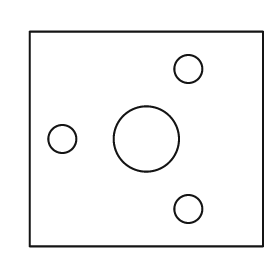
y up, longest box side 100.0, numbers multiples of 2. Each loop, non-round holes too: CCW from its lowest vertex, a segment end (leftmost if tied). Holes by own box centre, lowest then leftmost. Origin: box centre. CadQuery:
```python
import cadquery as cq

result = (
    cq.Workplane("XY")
    .moveTo(-50.0, -46.0)
    .lineTo(50.0, -46.0)
    .lineTo(50.0, 46.0)
    .lineTo(-50.0, 46.0)
    .close()
    .moveTo(18.0, -30.0)
    .circle(6.0)
    .moveTo(-36.0, 0.0)
    .circle(6.0)
    .moveTo(0.0, 0.0)
    .circle(14.0)
    .moveTo(18.0, 30.0)
    .circle(6.0)
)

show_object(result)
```